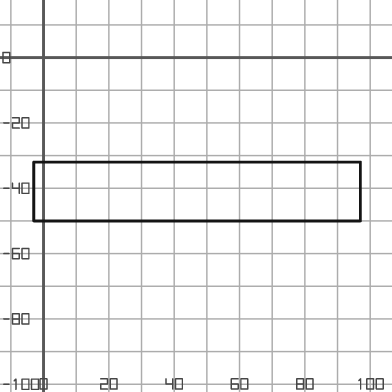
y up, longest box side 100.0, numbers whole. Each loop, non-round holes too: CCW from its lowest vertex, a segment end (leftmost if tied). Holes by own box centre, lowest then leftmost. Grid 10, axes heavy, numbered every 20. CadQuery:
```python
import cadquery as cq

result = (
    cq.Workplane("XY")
    .moveTo(-3.0, -50.0)
    .lineTo(97.0, -50.0)
    .lineTo(97.0, -32.0)
    .lineTo(-3.0, -32.0)
    .close()
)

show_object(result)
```